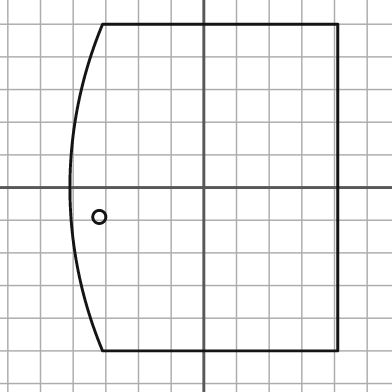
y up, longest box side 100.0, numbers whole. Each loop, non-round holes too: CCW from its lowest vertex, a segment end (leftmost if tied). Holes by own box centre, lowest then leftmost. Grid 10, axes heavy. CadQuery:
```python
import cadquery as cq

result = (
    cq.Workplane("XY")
    .moveTo(-31.0, -50.0)
    .lineTo(41.0, -50.0)
    .lineTo(41.0, 50.0)
    .lineTo(-31.0, 50.0)
    .threePointArc((-41.0, 0.0), (-31.0, -50.0))
    .close()
    .moveTo(-32.0, -9.0)
    .circle(2.0)
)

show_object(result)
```